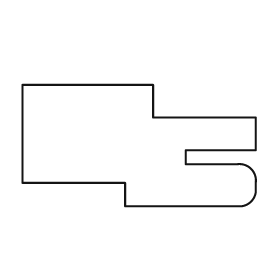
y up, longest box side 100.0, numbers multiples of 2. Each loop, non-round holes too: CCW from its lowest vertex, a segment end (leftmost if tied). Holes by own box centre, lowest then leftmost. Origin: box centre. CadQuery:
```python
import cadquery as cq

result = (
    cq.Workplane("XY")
    .moveTo(-6.0, -26.0)
    .lineTo(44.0, -26.0)
    .threePointArc((48.0, -24.0), (50.0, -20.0))
    .lineTo(50.0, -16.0)
    .threePointArc((48.0, -10.0), (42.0, -8.0))
    .lineTo(20.0, -8.0)
    .lineTo(20.0, -2.0)
    .lineTo(50.0, -2.0)
    .lineTo(50.0, 12.0)
    .lineTo(6.0, 12.0)
    .lineTo(6.0, 26.0)
    .lineTo(-50.0, 26.0)
    .lineTo(-50.0, -16.0)
    .lineTo(-6.0, -16.0)
    .close()
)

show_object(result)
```